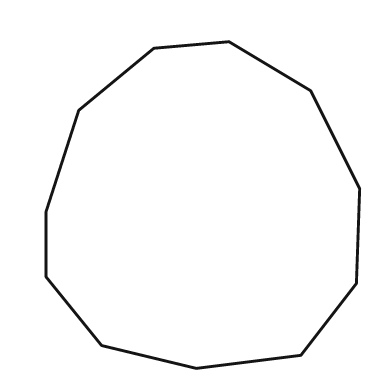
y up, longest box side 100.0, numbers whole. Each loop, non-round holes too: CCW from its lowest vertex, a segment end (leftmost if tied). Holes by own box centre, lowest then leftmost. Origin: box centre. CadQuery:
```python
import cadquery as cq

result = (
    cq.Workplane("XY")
    .moveTo(-2.0, -50.0)
    .lineTo(30.0, -46.0)
    .lineTo(47.0, -24.0)
    .lineTo(48.0, 5.0)
    .lineTo(33.0, 35.0)
    .lineTo(8.0, 50.0)
    .lineTo(-15.0, 48.0)
    .lineTo(-38.0, 29.0)
    .lineTo(-48.0, -2.0)
    .lineTo(-48.0, -22.0)
    .lineTo(-31.0, -43.0)
    .close()
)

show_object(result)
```